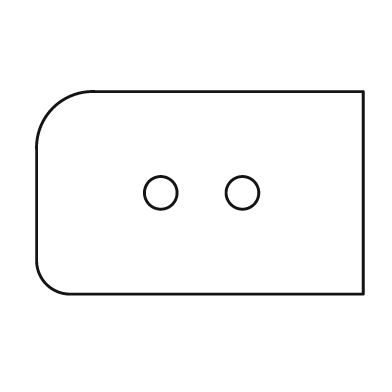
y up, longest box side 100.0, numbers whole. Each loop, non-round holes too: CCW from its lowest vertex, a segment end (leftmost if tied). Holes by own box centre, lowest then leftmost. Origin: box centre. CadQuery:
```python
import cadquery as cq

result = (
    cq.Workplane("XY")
    .moveTo(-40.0, -31.0)
    .lineTo(50.0, -31.0)
    .lineTo(50.0, 31.0)
    .lineTo(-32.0, 31.0)
    .threePointArc((-45.0, 26.0), (-50.0, 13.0))
    .lineTo(-50.0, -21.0)
    .threePointArc((-47.0, -28.0), (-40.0, -31.0))
    .close()
    .moveTo(-12.0, 0.0)
    .circle(5.0)
    .moveTo(13.0, 0.0)
    .circle(5.0)
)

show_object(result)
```